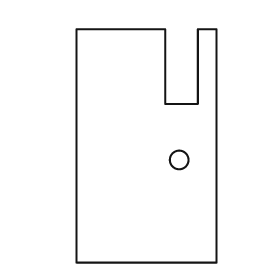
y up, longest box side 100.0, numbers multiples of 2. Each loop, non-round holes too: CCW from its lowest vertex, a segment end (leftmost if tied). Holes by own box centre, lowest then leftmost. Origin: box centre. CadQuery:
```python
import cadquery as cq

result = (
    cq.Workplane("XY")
    .moveTo(-30.0, -50.0)
    .lineTo(30.0, -50.0)
    .lineTo(30.0, 50.0)
    .lineTo(22.0, 50.0)
    .lineTo(22.0, 18.0)
    .lineTo(8.0, 18.0)
    .lineTo(8.0, 50.0)
    .lineTo(-30.0, 50.0)
    .close()
    .moveTo(14.0, -6.0)
    .circle(4.0)
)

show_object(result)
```